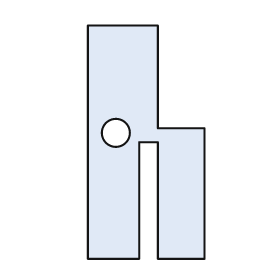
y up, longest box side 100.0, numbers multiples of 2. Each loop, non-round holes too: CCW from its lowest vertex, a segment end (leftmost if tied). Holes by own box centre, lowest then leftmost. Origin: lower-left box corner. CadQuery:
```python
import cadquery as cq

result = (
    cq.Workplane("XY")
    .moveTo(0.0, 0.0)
    .lineTo(22.0, 0.0)
    .lineTo(22.0, 50.0)
    .lineTo(30.0, 50.0)
    .lineTo(30.0, 0.0)
    .lineTo(50.0, 0.0)
    .lineTo(50.0, 56.0)
    .lineTo(30.0, 56.0)
    .lineTo(30.0, 100.0)
    .lineTo(0.0, 100.0)
    .close()
    .moveTo(12.0, 54.0)
    .circle(6.0)
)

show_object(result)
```